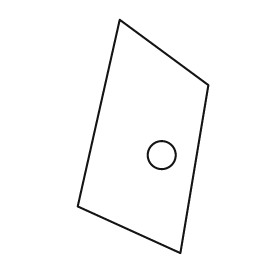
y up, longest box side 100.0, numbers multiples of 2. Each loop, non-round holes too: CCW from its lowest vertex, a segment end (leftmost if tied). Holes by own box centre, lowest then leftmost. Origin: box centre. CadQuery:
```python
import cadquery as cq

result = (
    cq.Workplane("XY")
    .moveTo(16.0, -50.0)
    .lineTo(28.0, 22.0)
    .lineTo(-10.0, 50.0)
    .lineTo(-28.0, -30.0)
    .close()
    .moveTo(8.0, -8.0)
    .circle(6.0)
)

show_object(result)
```